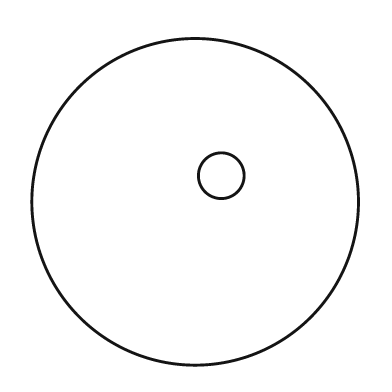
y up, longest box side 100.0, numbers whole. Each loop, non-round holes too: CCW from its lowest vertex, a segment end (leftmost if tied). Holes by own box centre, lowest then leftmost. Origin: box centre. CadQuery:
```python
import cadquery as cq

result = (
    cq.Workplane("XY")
    .moveTo(0.0, 0.0)
    .circle(50.0)
    .moveTo(8.0, 8.0)
    .circle(7.0)
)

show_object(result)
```